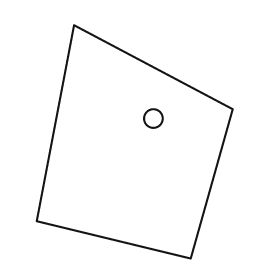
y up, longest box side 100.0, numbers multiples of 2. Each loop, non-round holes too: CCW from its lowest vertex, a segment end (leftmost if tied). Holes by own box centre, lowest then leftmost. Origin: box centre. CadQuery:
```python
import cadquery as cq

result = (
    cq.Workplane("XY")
    .moveTo(24.0, -50.0)
    .lineTo(42.0, 14.0)
    .lineTo(-26.0, 50.0)
    .lineTo(-42.0, -34.0)
    .close()
    .moveTo(8.0, 10.0)
    .circle(4.0)
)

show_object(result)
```